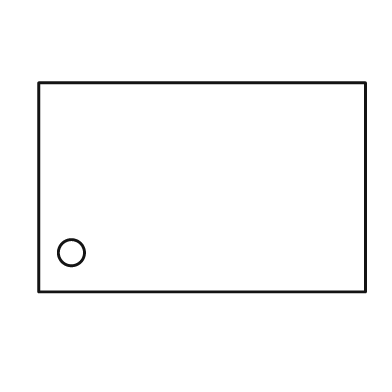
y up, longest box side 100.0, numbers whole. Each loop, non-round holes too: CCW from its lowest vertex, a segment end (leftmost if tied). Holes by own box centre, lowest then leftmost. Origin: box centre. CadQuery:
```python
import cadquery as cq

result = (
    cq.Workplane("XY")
    .moveTo(-50.0, -32.0)
    .lineTo(50.0, -32.0)
    .lineTo(50.0, 32.0)
    .lineTo(-50.0, 32.0)
    .close()
    .moveTo(-40.0, -20.0)
    .circle(4.0)
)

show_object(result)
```